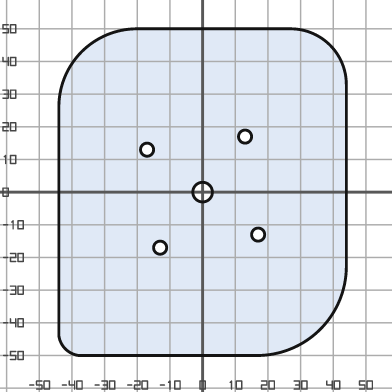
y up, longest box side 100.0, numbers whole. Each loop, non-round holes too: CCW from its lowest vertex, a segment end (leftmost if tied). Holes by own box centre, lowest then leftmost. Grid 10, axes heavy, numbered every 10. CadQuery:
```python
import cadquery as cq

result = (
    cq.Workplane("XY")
    .moveTo(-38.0, -50.0)
    .lineTo(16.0, -50.0)
    .threePointArc((36.0, -42.0), (44.0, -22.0))
    .lineTo(44.0, 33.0)
    .threePointArc((39.0, 45.0), (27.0, 50.0))
    .lineTo(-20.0, 50.0)
    .threePointArc((-37.0, 43.0), (-44.0, 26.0))
    .lineTo(-44.0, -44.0)
    .threePointArc((-42.0, -48.0), (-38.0, -50.0))
    .close()
    .moveTo(-13.0, -17.0)
    .circle(2.0)
    .moveTo(17.0, -13.0)
    .circle(2.0)
    .moveTo(0.0, 0.0)
    .circle(3.0)
    .moveTo(-17.0, 13.0)
    .circle(2.0)
    .moveTo(13.0, 17.0)
    .circle(2.0)
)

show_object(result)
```